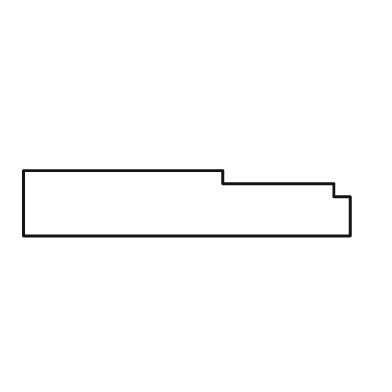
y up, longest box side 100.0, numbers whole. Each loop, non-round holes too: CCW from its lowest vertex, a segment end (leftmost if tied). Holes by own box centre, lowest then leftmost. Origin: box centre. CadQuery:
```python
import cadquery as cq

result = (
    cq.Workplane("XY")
    .moveTo(-50.0, -10.0)
    .lineTo(50.0, -10.0)
    .lineTo(50.0, 2.0)
    .lineTo(45.0, 2.0)
    .lineTo(45.0, 6.0)
    .lineTo(11.0, 6.0)
    .lineTo(11.0, 10.0)
    .lineTo(-50.0, 10.0)
    .close()
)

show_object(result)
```